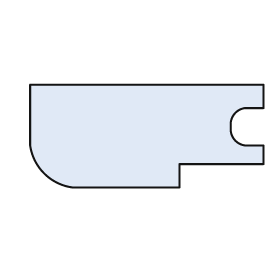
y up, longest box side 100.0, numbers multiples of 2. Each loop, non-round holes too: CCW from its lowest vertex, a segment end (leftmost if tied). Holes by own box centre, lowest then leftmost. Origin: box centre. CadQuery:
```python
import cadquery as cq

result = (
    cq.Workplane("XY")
    .moveTo(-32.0, -22.0)
    .lineTo(14.0, -22.0)
    .lineTo(14.0, -12.0)
    .lineTo(50.0, -12.0)
    .lineTo(50.0, -4.0)
    .lineTo(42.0, -4.0)
    .threePointArc((38.0, -2.0), (36.0, 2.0))
    .lineTo(36.0, 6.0)
    .threePointArc((38.0, 10.0), (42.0, 12.0))
    .lineTo(50.0, 12.0)
    .lineTo(50.0, 22.0)
    .lineTo(-50.0, 22.0)
    .lineTo(-50.0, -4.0)
    .threePointArc((-44.0, -16.0), (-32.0, -22.0))
    .close()
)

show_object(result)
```